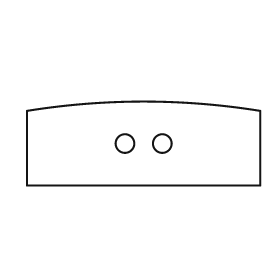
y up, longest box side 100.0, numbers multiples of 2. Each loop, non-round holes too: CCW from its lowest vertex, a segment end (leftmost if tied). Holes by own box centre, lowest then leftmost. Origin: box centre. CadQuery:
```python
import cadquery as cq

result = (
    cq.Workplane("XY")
    .moveTo(-50.0, -18.0)
    .lineTo(50.0, -18.0)
    .lineTo(50.0, 14.0)
    .threePointArc((0.0, 18.0), (-50.0, 14.0))
    .close()
    .moveTo(-8.0, 0.0)
    .circle(4.0)
    .moveTo(8.0, 0.0)
    .circle(4.0)
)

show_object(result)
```